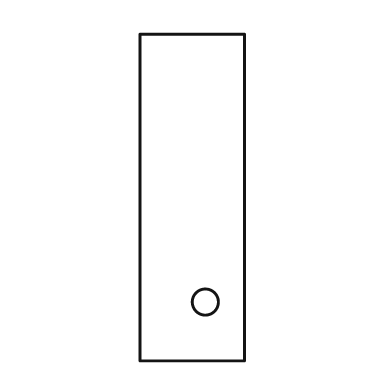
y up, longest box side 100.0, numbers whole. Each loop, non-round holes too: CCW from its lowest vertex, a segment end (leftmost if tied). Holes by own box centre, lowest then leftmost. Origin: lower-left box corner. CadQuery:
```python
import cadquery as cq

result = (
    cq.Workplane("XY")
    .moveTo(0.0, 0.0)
    .lineTo(32.0, 0.0)
    .lineTo(32.0, 100.0)
    .lineTo(0.0, 100.0)
    .close()
    .moveTo(20.0, 18.0)
    .circle(4.0)
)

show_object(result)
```